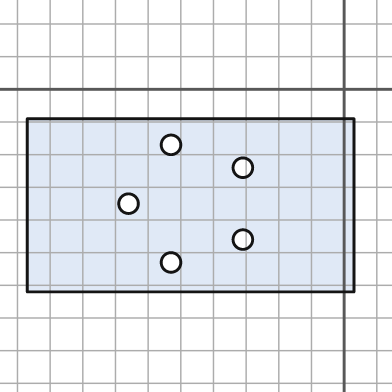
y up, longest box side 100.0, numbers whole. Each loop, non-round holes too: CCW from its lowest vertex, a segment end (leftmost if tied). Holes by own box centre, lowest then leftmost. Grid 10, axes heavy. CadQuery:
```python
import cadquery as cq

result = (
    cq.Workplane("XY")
    .moveTo(-97.0, -62.0)
    .lineTo(3.0, -62.0)
    .lineTo(3.0, -9.0)
    .lineTo(-97.0, -9.0)
    .close()
    .moveTo(-53.0, -53.0)
    .circle(3.0)
    .moveTo(-31.0, -46.0)
    .circle(3.0)
    .moveTo(-66.0, -35.0)
    .circle(3.0)
    .moveTo(-31.0, -24.0)
    .circle(3.0)
    .moveTo(-53.0, -17.0)
    .circle(3.0)
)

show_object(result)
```